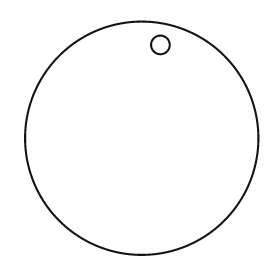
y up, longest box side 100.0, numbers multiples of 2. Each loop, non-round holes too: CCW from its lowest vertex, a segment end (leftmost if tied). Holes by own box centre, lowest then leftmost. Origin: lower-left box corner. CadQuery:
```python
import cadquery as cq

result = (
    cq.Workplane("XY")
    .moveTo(50.0, 50.0)
    .circle(50.0)
    .moveTo(58.0, 90.0)
    .circle(4.0)
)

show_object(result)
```